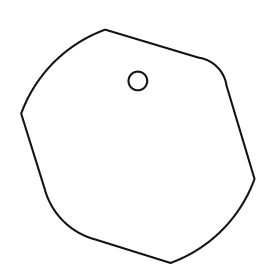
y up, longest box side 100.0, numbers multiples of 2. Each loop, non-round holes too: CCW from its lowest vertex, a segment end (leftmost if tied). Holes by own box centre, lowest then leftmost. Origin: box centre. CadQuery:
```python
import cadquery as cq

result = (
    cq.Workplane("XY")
    .moveTo(14.0, -50.0)
    .threePointArc((36.0, -36.0), (50.0, -14.0))
    .lineTo(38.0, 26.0)
    .threePointArc((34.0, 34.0), (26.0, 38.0))
    .lineTo(-14.0, 50.0)
    .threePointArc((-36.0, 36.0), (-50.0, 14.0))
    .lineTo(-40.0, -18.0)
    .threePointArc((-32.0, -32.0), (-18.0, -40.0))
    .close()
    .moveTo(0.0, 28.0)
    .circle(4.0)
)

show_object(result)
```